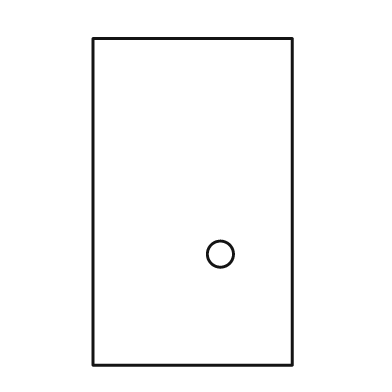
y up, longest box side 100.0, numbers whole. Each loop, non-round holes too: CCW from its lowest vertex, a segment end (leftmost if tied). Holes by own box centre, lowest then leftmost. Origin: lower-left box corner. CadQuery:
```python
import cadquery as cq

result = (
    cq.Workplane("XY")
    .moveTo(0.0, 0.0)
    .lineTo(61.0, 0.0)
    .lineTo(61.0, 100.0)
    .lineTo(0.0, 100.0)
    .close()
    .moveTo(39.0, 34.0)
    .circle(4.0)
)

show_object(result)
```